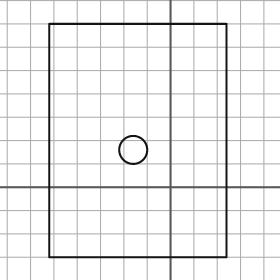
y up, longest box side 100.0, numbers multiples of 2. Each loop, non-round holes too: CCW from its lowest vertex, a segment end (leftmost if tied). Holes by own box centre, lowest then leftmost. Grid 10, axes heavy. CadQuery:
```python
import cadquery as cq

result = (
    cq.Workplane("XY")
    .moveTo(-52.0, -30.0)
    .lineTo(24.0, -30.0)
    .lineTo(24.0, 70.0)
    .lineTo(-52.0, 70.0)
    .close()
    .moveTo(-16.0, 16.0)
    .circle(6.0)
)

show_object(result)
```